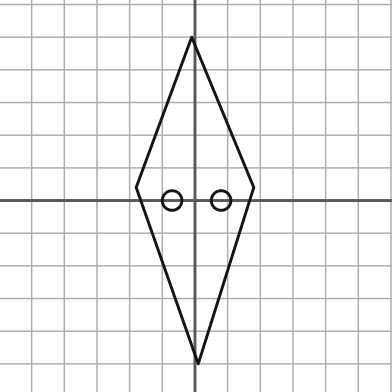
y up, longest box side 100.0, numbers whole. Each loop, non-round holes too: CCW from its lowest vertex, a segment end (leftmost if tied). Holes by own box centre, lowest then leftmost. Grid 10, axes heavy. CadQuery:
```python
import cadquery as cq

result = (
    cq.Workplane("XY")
    .moveTo(1.0, -50.0)
    .lineTo(18.0, 4.0)
    .lineTo(-1.0, 50.0)
    .lineTo(-18.0, 4.0)
    .close()
    .moveTo(-7.0, 0.0)
    .circle(3.0)
    .moveTo(8.0, 0.0)
    .circle(3.0)
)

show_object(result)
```